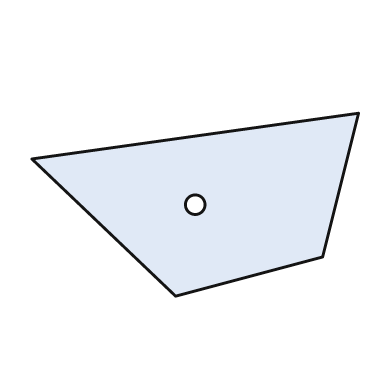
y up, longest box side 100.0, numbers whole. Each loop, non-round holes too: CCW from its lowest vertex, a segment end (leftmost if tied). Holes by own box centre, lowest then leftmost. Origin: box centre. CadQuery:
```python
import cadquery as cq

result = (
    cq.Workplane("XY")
    .moveTo(-6.0, -28.0)
    .lineTo(39.0, -16.0)
    .lineTo(50.0, 28.0)
    .lineTo(-50.0, 14.0)
    .close()
    .moveTo(0.0, 0.0)
    .circle(3.0)
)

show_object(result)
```